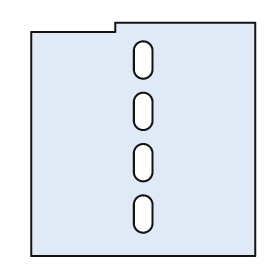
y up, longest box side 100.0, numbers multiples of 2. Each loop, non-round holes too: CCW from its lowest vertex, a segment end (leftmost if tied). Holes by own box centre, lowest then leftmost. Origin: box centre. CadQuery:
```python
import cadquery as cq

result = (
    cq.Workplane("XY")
    .moveTo(-48.0, -50.0)
    .lineTo(48.0, -50.0)
    .lineTo(48.0, 50.0)
    .lineTo(-12.0, 50.0)
    .lineTo(-12.0, 46.0)
    .lineTo(-48.0, 46.0)
    .close()
    .moveTo(-4.0, -36.0)
    .threePointArc((0.0, -40.0), (4.0, -36.0))
    .lineTo(4.0, -28.0)
    .threePointArc((0.0, -24.0), (-4.0, -28.0))
    .close()
    .moveTo(-4.0, -14.0)
    .threePointArc((0.0, -18.0), (4.0, -14.0))
    .lineTo(4.0, -6.0)
    .threePointArc((0.0, -2.0), (-4.0, -6.0))
    .close()
    .moveTo(-4.0, 8.0)
    .threePointArc((0.0, 4.0), (4.0, 8.0))
    .lineTo(4.0, 16.0)
    .threePointArc((0.0, 20.0), (-4.0, 16.0))
    .close()
    .moveTo(-4.0, 30.0)
    .threePointArc((0.0, 26.0), (4.0, 30.0))
    .lineTo(4.0, 38.0)
    .threePointArc((0.0, 42.0), (-4.0, 38.0))
    .close()
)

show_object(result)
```